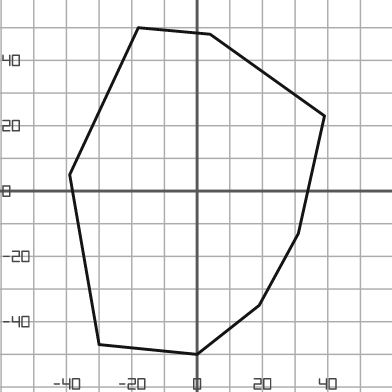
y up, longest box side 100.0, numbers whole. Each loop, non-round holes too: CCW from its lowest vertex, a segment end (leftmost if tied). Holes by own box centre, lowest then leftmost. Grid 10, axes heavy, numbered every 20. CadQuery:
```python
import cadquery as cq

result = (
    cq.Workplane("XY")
    .moveTo(0.0, -50.0)
    .lineTo(19.0, -35.0)
    .lineTo(31.0, -13.0)
    .lineTo(39.0, 23.0)
    .lineTo(4.0, 48.0)
    .lineTo(-18.0, 50.0)
    .lineTo(-39.0, 5.0)
    .lineTo(-30.0, -47.0)
    .close()
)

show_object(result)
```